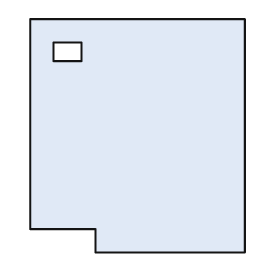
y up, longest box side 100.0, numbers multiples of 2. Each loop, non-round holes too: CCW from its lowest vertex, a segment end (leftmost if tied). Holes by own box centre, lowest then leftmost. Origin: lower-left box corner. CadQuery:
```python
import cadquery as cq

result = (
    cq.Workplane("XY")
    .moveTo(28.0, 0.0)
    .lineTo(92.0, 0.0)
    .lineTo(92.0, 100.0)
    .lineTo(0.0, 100.0)
    .lineTo(0.0, 10.0)
    .lineTo(28.0, 10.0)
    .close()
    .moveTo(10.0, 82.0)
    .lineTo(22.0, 82.0)
    .lineTo(22.0, 90.0)
    .lineTo(10.0, 90.0)
    .close()
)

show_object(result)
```